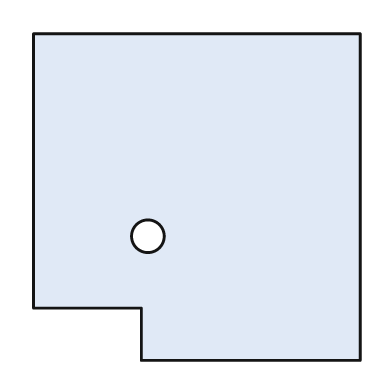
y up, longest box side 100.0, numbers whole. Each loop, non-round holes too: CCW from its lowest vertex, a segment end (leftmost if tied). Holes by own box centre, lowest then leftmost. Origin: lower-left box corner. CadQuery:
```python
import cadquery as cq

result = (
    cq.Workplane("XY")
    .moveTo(33.0, 0.0)
    .lineTo(100.0, 0.0)
    .lineTo(100.0, 100.0)
    .lineTo(0.0, 100.0)
    .lineTo(0.0, 16.0)
    .lineTo(33.0, 16.0)
    .close()
    .moveTo(35.0, 38.0)
    .circle(5.0)
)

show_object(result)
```